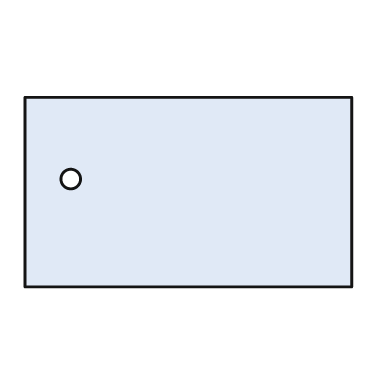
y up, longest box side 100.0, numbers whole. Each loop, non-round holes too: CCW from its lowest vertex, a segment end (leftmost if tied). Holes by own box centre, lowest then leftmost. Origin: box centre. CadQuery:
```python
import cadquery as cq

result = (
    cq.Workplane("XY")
    .moveTo(-50.0, -29.0)
    .lineTo(50.0, -29.0)
    .lineTo(50.0, 29.0)
    .lineTo(-50.0, 29.0)
    .close()
    .moveTo(-36.0, 4.0)
    .circle(3.0)
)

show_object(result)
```